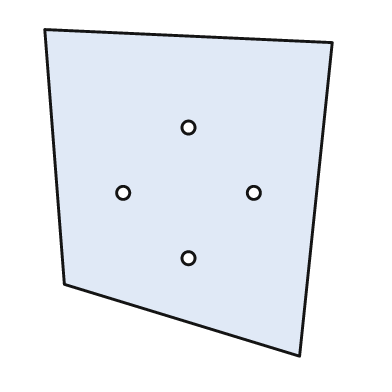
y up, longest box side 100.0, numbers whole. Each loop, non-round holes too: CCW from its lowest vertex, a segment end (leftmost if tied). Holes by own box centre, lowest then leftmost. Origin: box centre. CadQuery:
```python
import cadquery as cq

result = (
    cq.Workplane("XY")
    .moveTo(34.0, -50.0)
    .lineTo(44.0, 46.0)
    .lineTo(-44.0, 50.0)
    .lineTo(-38.0, -28.0)
    .close()
    .moveTo(0.0, -20.0)
    .circle(2.0)
    .moveTo(-20.0, 0.0)
    .circle(2.0)
    .moveTo(20.0, 0.0)
    .circle(2.0)
    .moveTo(0.0, 20.0)
    .circle(2.0)
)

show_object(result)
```